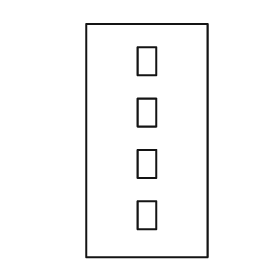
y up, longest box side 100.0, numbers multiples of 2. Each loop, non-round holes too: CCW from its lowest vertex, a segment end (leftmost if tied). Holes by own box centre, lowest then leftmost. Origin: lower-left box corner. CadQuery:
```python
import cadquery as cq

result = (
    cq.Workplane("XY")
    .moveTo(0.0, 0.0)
    .lineTo(52.0, 0.0)
    .lineTo(52.0, 100.0)
    .lineTo(0.0, 100.0)
    .close()
    .moveTo(22.0, 12.0)
    .lineTo(30.0, 12.0)
    .lineTo(30.0, 24.0)
    .lineTo(22.0, 24.0)
    .close()
    .moveTo(22.0, 34.0)
    .lineTo(30.0, 34.0)
    .lineTo(30.0, 46.0)
    .lineTo(22.0, 46.0)
    .close()
    .moveTo(22.0, 56.0)
    .lineTo(30.0, 56.0)
    .lineTo(30.0, 68.0)
    .lineTo(22.0, 68.0)
    .close()
    .moveTo(22.0, 78.0)
    .lineTo(30.0, 78.0)
    .lineTo(30.0, 90.0)
    .lineTo(22.0, 90.0)
    .close()
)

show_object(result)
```